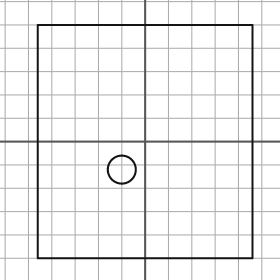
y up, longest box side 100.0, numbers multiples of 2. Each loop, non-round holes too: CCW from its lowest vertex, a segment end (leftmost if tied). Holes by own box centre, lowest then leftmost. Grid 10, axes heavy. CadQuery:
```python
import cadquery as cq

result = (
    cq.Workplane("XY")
    .moveTo(-46.0, -50.0)
    .lineTo(46.0, -50.0)
    .lineTo(46.0, 50.0)
    .lineTo(-46.0, 50.0)
    .close()
    .moveTo(-10.0, -12.0)
    .circle(6.0)
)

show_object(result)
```